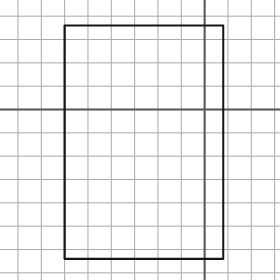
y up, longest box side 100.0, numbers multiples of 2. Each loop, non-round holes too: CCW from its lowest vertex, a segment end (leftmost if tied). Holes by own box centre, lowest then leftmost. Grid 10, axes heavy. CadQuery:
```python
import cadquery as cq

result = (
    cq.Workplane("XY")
    .moveTo(-60.0, -64.0)
    .lineTo(8.0, -64.0)
    .lineTo(8.0, 36.0)
    .lineTo(-60.0, 36.0)
    .close()
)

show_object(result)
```